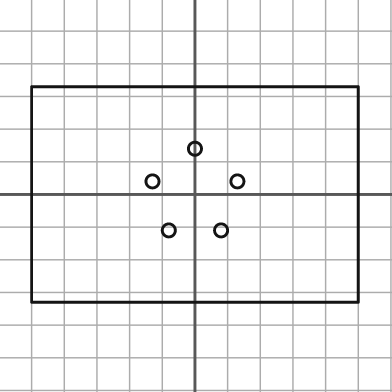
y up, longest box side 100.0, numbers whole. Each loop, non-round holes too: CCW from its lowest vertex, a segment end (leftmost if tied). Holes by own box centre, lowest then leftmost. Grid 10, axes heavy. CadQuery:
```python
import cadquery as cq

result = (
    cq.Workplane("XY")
    .moveTo(-50.0, -33.0)
    .lineTo(50.0, -33.0)
    .lineTo(50.0, 33.0)
    .lineTo(-50.0, 33.0)
    .close()
    .moveTo(-8.0, -11.0)
    .circle(2.0)
    .moveTo(8.0, -11.0)
    .circle(2.0)
    .moveTo(-13.0, 4.0)
    .circle(2.0)
    .moveTo(13.0, 4.0)
    .circle(2.0)
    .moveTo(0.0, 14.0)
    .circle(2.0)
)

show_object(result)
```